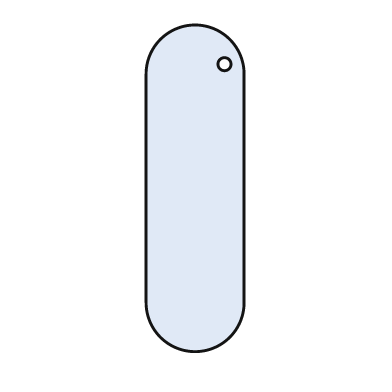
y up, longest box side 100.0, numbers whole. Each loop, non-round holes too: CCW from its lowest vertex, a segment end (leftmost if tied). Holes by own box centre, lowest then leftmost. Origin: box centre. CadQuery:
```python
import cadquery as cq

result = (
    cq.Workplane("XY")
    .moveTo(-15.0, -35.0)
    .threePointArc((0.0, -50.0), (15.0, -35.0))
    .lineTo(15.0, 35.0)
    .threePointArc((0.0, 50.0), (-15.0, 35.0))
    .close()
    .moveTo(9.0, 38.0)
    .circle(2.0)
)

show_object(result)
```